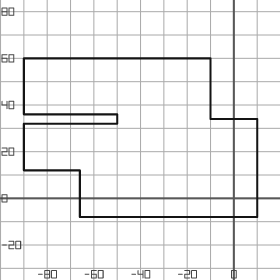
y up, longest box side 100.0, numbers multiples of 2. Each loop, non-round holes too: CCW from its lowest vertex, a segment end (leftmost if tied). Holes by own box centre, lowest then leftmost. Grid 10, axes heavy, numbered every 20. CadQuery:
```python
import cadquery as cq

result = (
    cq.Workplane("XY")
    .moveTo(-66.0, -8.0)
    .lineTo(10.0, -8.0)
    .lineTo(10.0, 34.0)
    .lineTo(-10.0, 34.0)
    .lineTo(-10.0, 60.0)
    .lineTo(-90.0, 60.0)
    .lineTo(-90.0, 36.0)
    .lineTo(-50.0, 36.0)
    .lineTo(-50.0, 32.0)
    .lineTo(-90.0, 32.0)
    .lineTo(-90.0, 12.0)
    .lineTo(-66.0, 12.0)
    .close()
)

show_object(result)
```